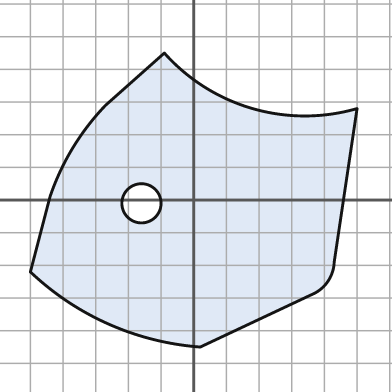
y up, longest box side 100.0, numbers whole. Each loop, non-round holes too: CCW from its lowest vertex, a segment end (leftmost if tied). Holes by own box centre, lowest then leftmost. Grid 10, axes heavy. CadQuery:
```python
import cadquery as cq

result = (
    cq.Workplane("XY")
    .moveTo(2.0, -45.0)
    .lineTo(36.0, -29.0)
    .threePointArc((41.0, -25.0), (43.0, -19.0))
    .lineTo(50.0, 28.0)
    .threePointArc((18.0, 28.0), (-9.0, 45.0))
    .lineTo(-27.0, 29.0)
    .threePointArc((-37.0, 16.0), (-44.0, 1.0))
    .lineTo(-50.0, -22.0)
    .threePointArc((-26.0, -38.0), (2.0, -45.0))
    .close()
    .moveTo(-16.0, -1.0)
    .circle(6.0)
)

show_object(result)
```